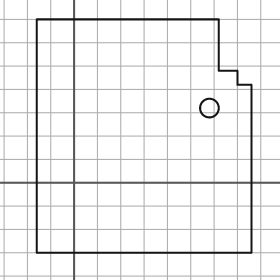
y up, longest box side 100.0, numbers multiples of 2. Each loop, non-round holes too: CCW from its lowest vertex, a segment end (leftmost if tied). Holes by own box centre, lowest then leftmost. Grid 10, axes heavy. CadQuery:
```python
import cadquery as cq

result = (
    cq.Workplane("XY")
    .moveTo(-16.0, -30.0)
    .lineTo(76.0, -30.0)
    .lineTo(76.0, 42.0)
    .lineTo(70.0, 42.0)
    .lineTo(70.0, 48.0)
    .lineTo(62.0, 48.0)
    .lineTo(62.0, 70.0)
    .lineTo(-16.0, 70.0)
    .close()
    .moveTo(58.0, 32.0)
    .circle(4.0)
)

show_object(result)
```